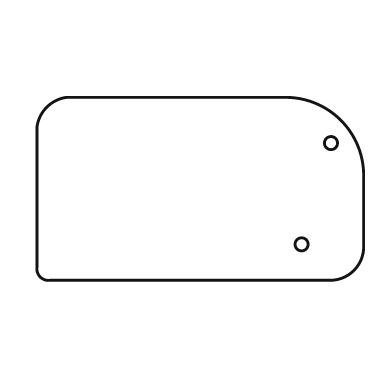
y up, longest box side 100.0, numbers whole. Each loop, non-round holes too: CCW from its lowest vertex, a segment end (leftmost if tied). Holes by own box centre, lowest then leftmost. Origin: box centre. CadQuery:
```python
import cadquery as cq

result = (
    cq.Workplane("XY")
    .moveTo(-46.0, -28.0)
    .lineTo(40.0, -28.0)
    .threePointArc((47.0, -25.0), (50.0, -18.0))
    .lineTo(50.0, 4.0)
    .threePointArc((43.0, 21.0), (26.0, 28.0))
    .lineTo(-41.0, 28.0)
    .threePointArc((-47.0, 25.0), (-50.0, 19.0))
    .lineTo(-50.0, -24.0)
    .threePointArc((-49.0, -27.0), (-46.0, -28.0))
    .close()
    .moveTo(31.0, -17.0)
    .circle(2.0)
    .moveTo(40.0, 14.0)
    .circle(2.0)
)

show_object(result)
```